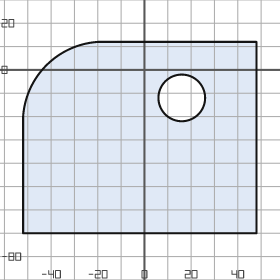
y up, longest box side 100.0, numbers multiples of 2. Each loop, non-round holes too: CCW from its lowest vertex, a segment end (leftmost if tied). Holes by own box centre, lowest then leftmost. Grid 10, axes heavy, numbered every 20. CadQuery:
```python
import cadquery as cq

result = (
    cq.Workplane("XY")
    .moveTo(-52.0, -70.0)
    .lineTo(48.0, -70.0)
    .lineTo(48.0, 12.0)
    .lineTo(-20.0, 12.0)
    .threePointArc((-42.0, 2.0), (-52.0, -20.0))
    .close()
    .moveTo(16.0, -12.0)
    .circle(10.0)
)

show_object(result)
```